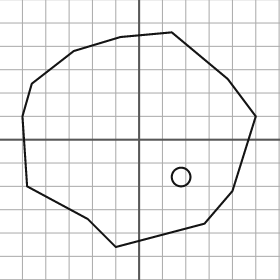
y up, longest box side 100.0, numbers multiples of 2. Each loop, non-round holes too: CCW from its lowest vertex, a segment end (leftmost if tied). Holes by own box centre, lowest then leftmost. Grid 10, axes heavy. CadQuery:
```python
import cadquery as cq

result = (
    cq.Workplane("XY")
    .moveTo(-10.0, -46.0)
    .lineTo(28.0, -36.0)
    .lineTo(40.0, -22.0)
    .lineTo(50.0, 10.0)
    .lineTo(38.0, 26.0)
    .lineTo(14.0, 46.0)
    .lineTo(-8.0, 44.0)
    .lineTo(-28.0, 38.0)
    .lineTo(-46.0, 24.0)
    .lineTo(-50.0, 10.0)
    .lineTo(-48.0, -20.0)
    .lineTo(-22.0, -34.0)
    .close()
    .moveTo(18.0, -16.0)
    .circle(4.0)
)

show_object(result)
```